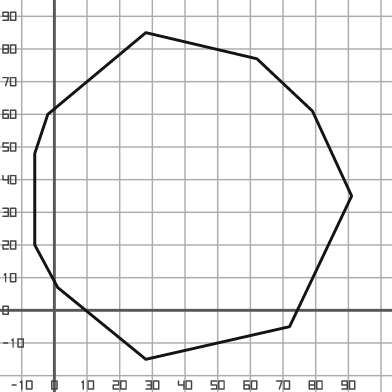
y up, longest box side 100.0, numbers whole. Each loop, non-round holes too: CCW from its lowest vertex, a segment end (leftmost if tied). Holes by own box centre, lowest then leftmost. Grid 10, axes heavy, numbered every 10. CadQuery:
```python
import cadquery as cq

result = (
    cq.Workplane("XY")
    .moveTo(28.0, -15.0)
    .lineTo(72.0, -5.0)
    .lineTo(91.0, 35.0)
    .lineTo(79.0, 61.0)
    .lineTo(62.0, 77.0)
    .lineTo(28.0, 85.0)
    .lineTo(-2.0, 60.0)
    .lineTo(-6.0, 48.0)
    .lineTo(-6.0, 20.0)
    .lineTo(1.0, 7.0)
    .close()
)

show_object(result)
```